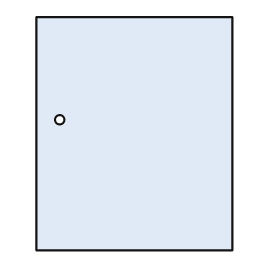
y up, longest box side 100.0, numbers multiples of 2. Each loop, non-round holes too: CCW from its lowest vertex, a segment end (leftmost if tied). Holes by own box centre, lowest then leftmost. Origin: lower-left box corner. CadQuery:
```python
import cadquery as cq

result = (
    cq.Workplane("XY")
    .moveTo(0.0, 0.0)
    .lineTo(84.0, 0.0)
    .lineTo(84.0, 100.0)
    .lineTo(0.0, 100.0)
    .close()
    .moveTo(10.0, 56.0)
    .circle(2.0)
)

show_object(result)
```